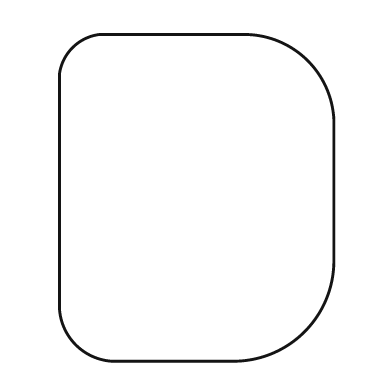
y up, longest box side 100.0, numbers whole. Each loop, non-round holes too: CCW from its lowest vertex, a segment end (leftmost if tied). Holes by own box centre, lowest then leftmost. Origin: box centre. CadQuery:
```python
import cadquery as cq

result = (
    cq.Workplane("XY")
    .moveTo(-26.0, -50.0)
    .lineTo(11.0, -50.0)
    .threePointArc((33.0, -41.0), (42.0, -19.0))
    .lineTo(42.0, 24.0)
    .threePointArc((34.0, 42.0), (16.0, 50.0))
    .lineTo(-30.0, 50.0)
    .threePointArc((-38.0, 46.0), (-42.0, 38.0))
    .lineTo(-42.0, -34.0)
    .threePointArc((-37.0, -45.0), (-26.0, -50.0))
    .close()
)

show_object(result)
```